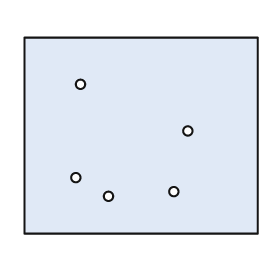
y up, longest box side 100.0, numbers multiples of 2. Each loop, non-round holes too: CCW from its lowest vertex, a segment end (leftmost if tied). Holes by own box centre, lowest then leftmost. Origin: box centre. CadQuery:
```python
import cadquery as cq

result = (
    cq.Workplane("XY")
    .moveTo(-50.0, -42.0)
    .lineTo(50.0, -42.0)
    .lineTo(50.0, 42.0)
    .lineTo(-50.0, 42.0)
    .close()
    .moveTo(-14.0, -26.0)
    .circle(2.0)
    .moveTo(14.0, -24.0)
    .circle(2.0)
    .moveTo(-28.0, -18.0)
    .circle(2.0)
    .moveTo(20.0, 2.0)
    .circle(2.0)
    .moveTo(-26.0, 22.0)
    .circle(2.0)
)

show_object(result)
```